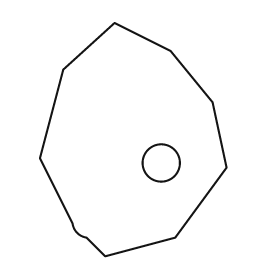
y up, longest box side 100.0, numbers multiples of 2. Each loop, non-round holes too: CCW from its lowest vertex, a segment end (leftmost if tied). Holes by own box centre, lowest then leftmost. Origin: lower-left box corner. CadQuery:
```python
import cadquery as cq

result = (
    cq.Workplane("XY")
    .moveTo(28.0, 0.0)
    .lineTo(58.0, 8.0)
    .lineTo(80.0, 38.0)
    .lineTo(74.0, 66.0)
    .lineTo(56.0, 88.0)
    .lineTo(32.0, 100.0)
    .lineTo(10.0, 80.0)
    .lineTo(0.0, 42.0)
    .lineTo(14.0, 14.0)
    .threePointArc((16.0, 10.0), (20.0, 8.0))
    .close()
    .moveTo(52.0, 40.0)
    .circle(8.0)
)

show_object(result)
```